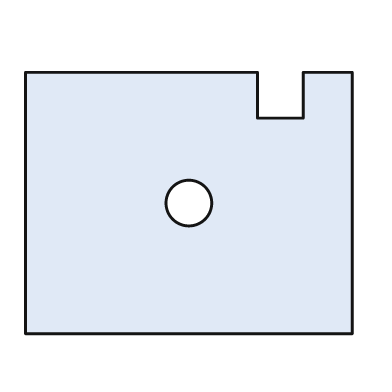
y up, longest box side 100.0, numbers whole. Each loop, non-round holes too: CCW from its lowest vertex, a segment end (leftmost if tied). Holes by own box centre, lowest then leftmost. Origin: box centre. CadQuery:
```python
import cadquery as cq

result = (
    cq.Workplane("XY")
    .moveTo(-50.0, -40.0)
    .lineTo(50.0, -40.0)
    .lineTo(50.0, 40.0)
    .lineTo(35.0, 40.0)
    .lineTo(35.0, 26.0)
    .lineTo(21.0, 26.0)
    .lineTo(21.0, 40.0)
    .lineTo(-50.0, 40.0)
    .close()
    .moveTo(0.0, 0.0)
    .circle(7.0)
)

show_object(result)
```